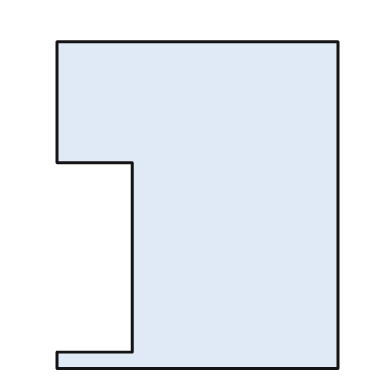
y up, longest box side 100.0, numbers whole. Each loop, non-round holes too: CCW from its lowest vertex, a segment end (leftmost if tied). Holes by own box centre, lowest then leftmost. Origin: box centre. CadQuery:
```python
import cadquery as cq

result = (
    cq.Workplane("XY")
    .moveTo(-43.0, -50.0)
    .lineTo(43.0, -50.0)
    .lineTo(43.0, 50.0)
    .lineTo(-43.0, 50.0)
    .lineTo(-43.0, 13.0)
    .lineTo(-20.0, 13.0)
    .lineTo(-20.0, -45.0)
    .lineTo(-43.0, -45.0)
    .close()
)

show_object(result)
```